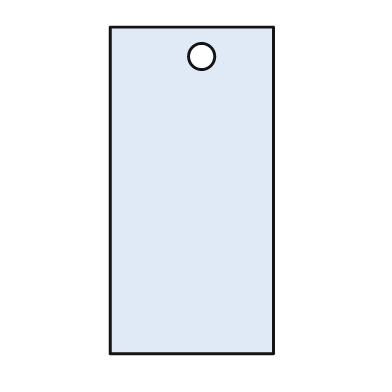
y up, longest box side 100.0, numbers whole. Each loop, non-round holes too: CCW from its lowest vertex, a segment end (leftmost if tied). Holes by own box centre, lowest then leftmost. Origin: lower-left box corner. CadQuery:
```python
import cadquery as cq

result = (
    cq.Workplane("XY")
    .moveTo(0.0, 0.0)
    .lineTo(50.0, 0.0)
    .lineTo(50.0, 100.0)
    .lineTo(0.0, 100.0)
    .close()
    .moveTo(28.0, 91.0)
    .circle(4.0)
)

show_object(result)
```